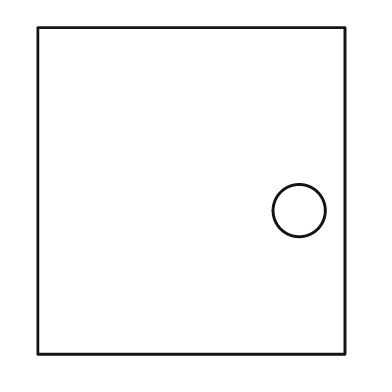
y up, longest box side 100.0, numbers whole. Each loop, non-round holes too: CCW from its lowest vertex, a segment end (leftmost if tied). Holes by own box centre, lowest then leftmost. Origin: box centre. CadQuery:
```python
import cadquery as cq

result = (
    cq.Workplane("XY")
    .moveTo(-47.0, -50.0)
    .lineTo(47.0, -50.0)
    .lineTo(47.0, 50.0)
    .lineTo(-47.0, 50.0)
    .close()
    .moveTo(33.0, -6.0)
    .circle(8.0)
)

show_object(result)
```